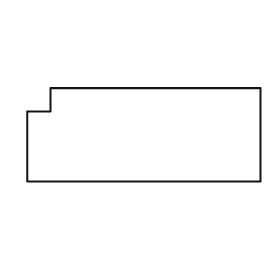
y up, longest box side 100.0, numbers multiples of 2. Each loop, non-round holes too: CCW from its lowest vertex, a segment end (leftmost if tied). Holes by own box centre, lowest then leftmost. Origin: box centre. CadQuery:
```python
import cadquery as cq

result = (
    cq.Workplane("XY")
    .moveTo(-50.0, -20.0)
    .lineTo(50.0, -20.0)
    .lineTo(50.0, 20.0)
    .lineTo(-40.0, 20.0)
    .lineTo(-40.0, 10.0)
    .lineTo(-50.0, 10.0)
    .close()
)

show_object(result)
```